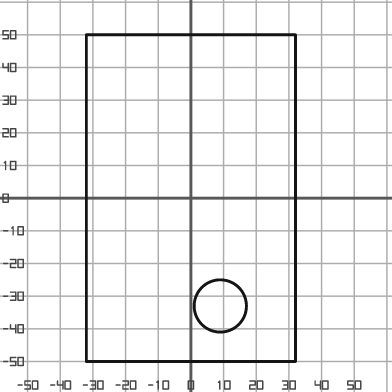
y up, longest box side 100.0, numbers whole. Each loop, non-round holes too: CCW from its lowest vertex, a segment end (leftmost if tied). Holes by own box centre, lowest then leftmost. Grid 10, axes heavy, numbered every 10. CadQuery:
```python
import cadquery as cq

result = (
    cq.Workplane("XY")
    .moveTo(-32.0, -50.0)
    .lineTo(32.0, -50.0)
    .lineTo(32.0, 50.0)
    .lineTo(-32.0, 50.0)
    .close()
    .moveTo(9.0, -33.0)
    .circle(8.0)
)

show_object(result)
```